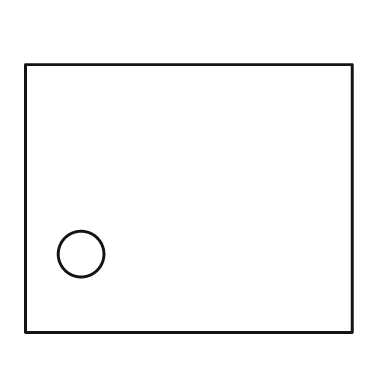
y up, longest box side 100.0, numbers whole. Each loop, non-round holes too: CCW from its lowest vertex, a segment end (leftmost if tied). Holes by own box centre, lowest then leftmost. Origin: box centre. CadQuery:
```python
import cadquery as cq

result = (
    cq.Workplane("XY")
    .moveTo(-50.0, -41.0)
    .lineTo(50.0, -41.0)
    .lineTo(50.0, 41.0)
    .lineTo(-50.0, 41.0)
    .close()
    .moveTo(-33.0, -17.0)
    .circle(7.0)
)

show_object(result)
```